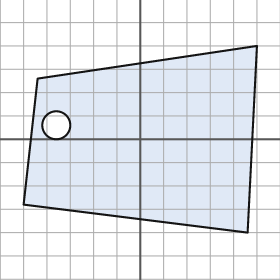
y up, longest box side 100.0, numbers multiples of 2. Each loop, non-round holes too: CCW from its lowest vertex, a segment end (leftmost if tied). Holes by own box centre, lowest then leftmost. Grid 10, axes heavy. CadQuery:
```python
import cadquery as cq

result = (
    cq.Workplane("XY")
    .moveTo(46.0, -40.0)
    .lineTo(50.0, 40.0)
    .lineTo(-44.0, 26.0)
    .lineTo(-50.0, -28.0)
    .close()
    .moveTo(-36.0, 6.0)
    .circle(6.0)
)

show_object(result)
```